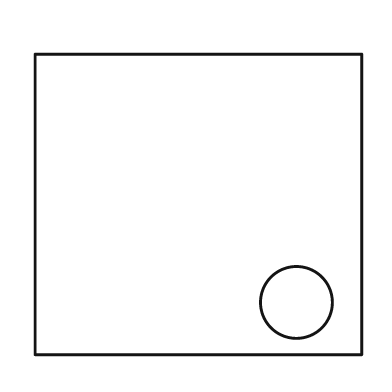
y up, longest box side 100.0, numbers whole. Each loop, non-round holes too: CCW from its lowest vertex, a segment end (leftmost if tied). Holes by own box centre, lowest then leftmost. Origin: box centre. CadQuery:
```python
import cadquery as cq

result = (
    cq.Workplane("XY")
    .moveTo(-50.0, -46.0)
    .lineTo(50.0, -46.0)
    .lineTo(50.0, 46.0)
    .lineTo(-50.0, 46.0)
    .close()
    .moveTo(30.0, -30.0)
    .circle(11.0)
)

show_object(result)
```